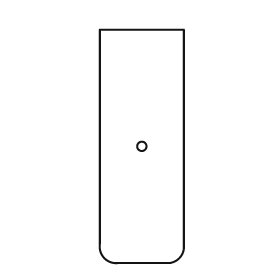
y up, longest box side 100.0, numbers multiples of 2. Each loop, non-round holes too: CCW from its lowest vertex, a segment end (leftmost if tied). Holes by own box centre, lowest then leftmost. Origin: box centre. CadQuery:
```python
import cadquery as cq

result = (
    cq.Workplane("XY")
    .moveTo(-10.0, -50.0)
    .lineTo(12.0, -50.0)
    .threePointArc((16.0, -48.0), (18.0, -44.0))
    .lineTo(18.0, 50.0)
    .lineTo(-18.0, 50.0)
    .lineTo(-18.0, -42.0)
    .threePointArc((-16.0, -48.0), (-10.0, -50.0))
    .close()
    .moveTo(0.0, 0.0)
    .circle(2.0)
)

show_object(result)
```